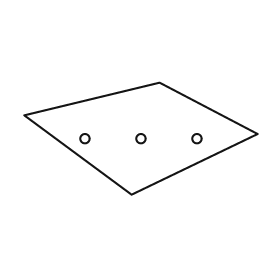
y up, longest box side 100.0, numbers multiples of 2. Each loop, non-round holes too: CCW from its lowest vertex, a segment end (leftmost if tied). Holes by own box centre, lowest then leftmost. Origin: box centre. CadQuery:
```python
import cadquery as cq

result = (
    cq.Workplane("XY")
    .moveTo(-4.0, -24.0)
    .lineTo(50.0, 2.0)
    .lineTo(8.0, 24.0)
    .lineTo(-50.0, 10.0)
    .close()
    .moveTo(-24.0, 0.0)
    .circle(2.0)
    .moveTo(0.0, 0.0)
    .circle(2.0)
    .moveTo(24.0, 0.0)
    .circle(2.0)
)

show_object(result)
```